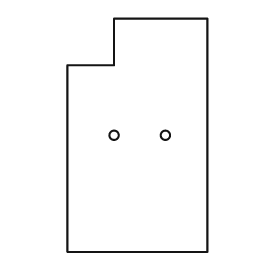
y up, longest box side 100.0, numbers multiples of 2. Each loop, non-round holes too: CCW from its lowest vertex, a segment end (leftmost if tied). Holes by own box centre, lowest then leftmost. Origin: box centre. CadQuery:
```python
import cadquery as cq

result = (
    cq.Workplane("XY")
    .moveTo(-30.0, -50.0)
    .lineTo(30.0, -50.0)
    .lineTo(30.0, 50.0)
    .lineTo(-10.0, 50.0)
    .lineTo(-10.0, 30.0)
    .lineTo(-30.0, 30.0)
    .close()
    .moveTo(-10.0, 0.0)
    .circle(2.0)
    .moveTo(12.0, 0.0)
    .circle(2.0)
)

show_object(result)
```